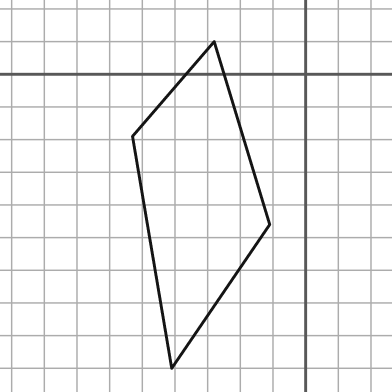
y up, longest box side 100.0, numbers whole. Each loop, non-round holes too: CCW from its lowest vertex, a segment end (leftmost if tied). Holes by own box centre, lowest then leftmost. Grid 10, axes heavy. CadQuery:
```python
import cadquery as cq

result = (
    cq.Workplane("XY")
    .moveTo(-41.0, -90.0)
    .lineTo(-11.0, -46.0)
    .lineTo(-28.0, 10.0)
    .lineTo(-53.0, -19.0)
    .close()
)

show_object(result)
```